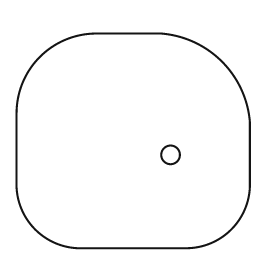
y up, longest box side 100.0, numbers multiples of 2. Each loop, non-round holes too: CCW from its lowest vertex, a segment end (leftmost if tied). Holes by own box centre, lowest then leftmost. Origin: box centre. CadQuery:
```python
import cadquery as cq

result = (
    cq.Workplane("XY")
    .moveTo(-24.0, -46.0)
    .lineTo(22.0, -46.0)
    .threePointArc((42.0, -38.0), (50.0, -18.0))
    .lineTo(50.0, 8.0)
    .threePointArc((38.0, 34.0), (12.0, 46.0))
    .lineTo(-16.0, 46.0)
    .threePointArc((-40.0, 36.0), (-50.0, 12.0))
    .lineTo(-50.0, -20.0)
    .threePointArc((-42.0, -38.0), (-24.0, -46.0))
    .close()
    .moveTo(16.0, -6.0)
    .circle(4.0)
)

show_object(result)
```